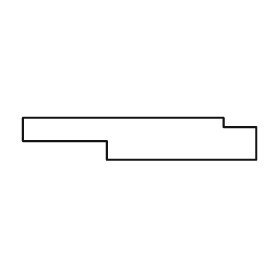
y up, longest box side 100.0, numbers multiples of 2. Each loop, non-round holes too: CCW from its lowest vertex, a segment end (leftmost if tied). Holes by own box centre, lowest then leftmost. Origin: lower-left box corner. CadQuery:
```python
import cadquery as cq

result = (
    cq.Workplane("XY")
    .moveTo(36.0, 0.0)
    .lineTo(100.0, 0.0)
    .lineTo(100.0, 14.0)
    .lineTo(86.0, 14.0)
    .lineTo(86.0, 18.0)
    .lineTo(0.0, 18.0)
    .lineTo(0.0, 8.0)
    .lineTo(36.0, 8.0)
    .close()
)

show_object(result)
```